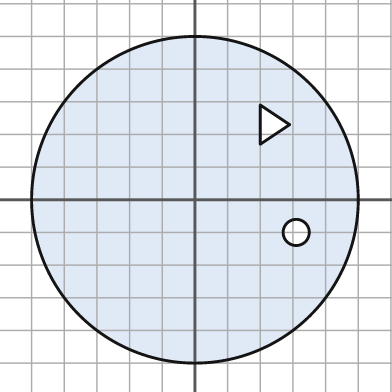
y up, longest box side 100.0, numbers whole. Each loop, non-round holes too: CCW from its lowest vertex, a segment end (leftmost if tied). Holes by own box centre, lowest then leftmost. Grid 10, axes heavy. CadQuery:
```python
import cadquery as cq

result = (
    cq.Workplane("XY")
    .moveTo(0.0, 0.0)
    .circle(50.0)
    .moveTo(31.0, -10.0)
    .circle(4.0)
    .moveTo(20.0, 17.0)
    .lineTo(29.0, 23.0)
    .lineTo(20.0, 29.0)
    .close()
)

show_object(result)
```